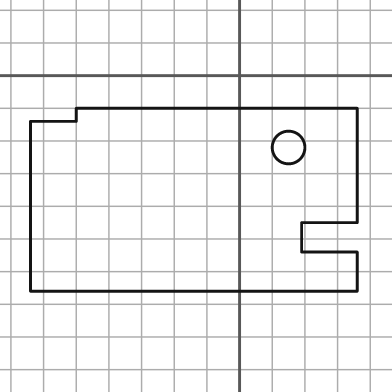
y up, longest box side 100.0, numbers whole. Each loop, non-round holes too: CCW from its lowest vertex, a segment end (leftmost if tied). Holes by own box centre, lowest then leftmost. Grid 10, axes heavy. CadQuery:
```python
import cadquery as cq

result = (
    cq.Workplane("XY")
    .moveTo(-64.0, -66.0)
    .lineTo(36.0, -66.0)
    .lineTo(36.0, -54.0)
    .lineTo(19.0, -54.0)
    .lineTo(19.0, -45.0)
    .lineTo(36.0, -45.0)
    .lineTo(36.0, -10.0)
    .lineTo(-50.0, -10.0)
    .lineTo(-50.0, -14.0)
    .lineTo(-64.0, -14.0)
    .close()
    .moveTo(15.0, -22.0)
    .circle(5.0)
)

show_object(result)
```